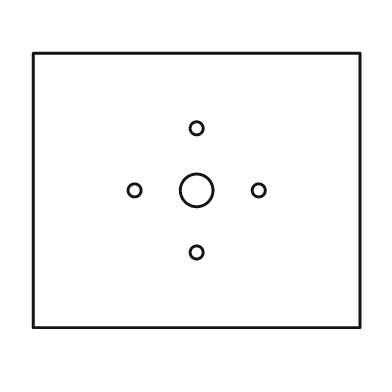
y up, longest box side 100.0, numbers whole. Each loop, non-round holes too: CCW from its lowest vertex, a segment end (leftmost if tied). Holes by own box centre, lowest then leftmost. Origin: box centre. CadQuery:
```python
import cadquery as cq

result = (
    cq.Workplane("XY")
    .moveTo(-50.0, -42.0)
    .lineTo(50.0, -42.0)
    .lineTo(50.0, 42.0)
    .lineTo(-50.0, 42.0)
    .close()
    .moveTo(0.0, -19.0)
    .circle(2.0)
    .moveTo(-19.0, 0.0)
    .circle(2.0)
    .moveTo(0.0, 0.0)
    .circle(5.0)
    .moveTo(19.0, 0.0)
    .circle(2.0)
    .moveTo(0.0, 19.0)
    .circle(2.0)
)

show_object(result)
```